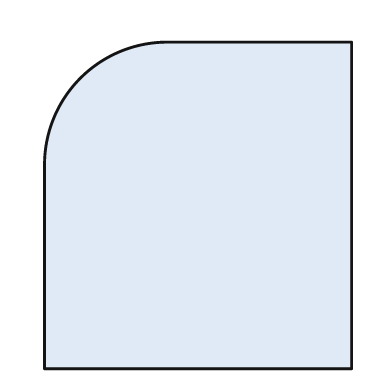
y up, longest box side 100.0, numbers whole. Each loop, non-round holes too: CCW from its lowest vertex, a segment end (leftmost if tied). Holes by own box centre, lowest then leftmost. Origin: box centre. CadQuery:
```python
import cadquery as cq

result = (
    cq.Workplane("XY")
    .moveTo(-47.0, -50.0)
    .lineTo(47.0, -50.0)
    .lineTo(47.0, 50.0)
    .lineTo(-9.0, 50.0)
    .threePointArc((-36.0, 39.0), (-47.0, 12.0))
    .close()
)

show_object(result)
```